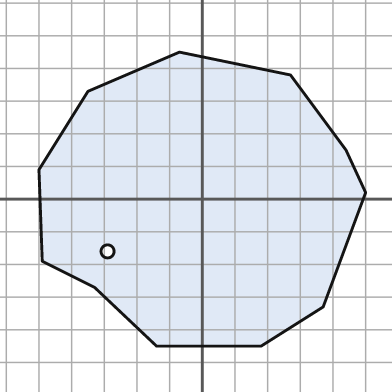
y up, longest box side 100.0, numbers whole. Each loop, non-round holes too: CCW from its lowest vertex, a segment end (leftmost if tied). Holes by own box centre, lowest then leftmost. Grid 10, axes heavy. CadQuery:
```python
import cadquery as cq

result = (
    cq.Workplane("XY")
    .moveTo(-14.0, -45.0)
    .lineTo(18.0, -45.0)
    .lineTo(37.0, -33.0)
    .lineTo(50.0, 2.0)
    .lineTo(44.0, 15.0)
    .lineTo(27.0, 38.0)
    .lineTo(-7.0, 45.0)
    .lineTo(-35.0, 33.0)
    .lineTo(-50.0, 9.0)
    .lineTo(-49.0, -19.0)
    .lineTo(-33.0, -27.0)
    .close()
    .moveTo(-29.0, -16.0)
    .circle(2.0)
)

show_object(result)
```